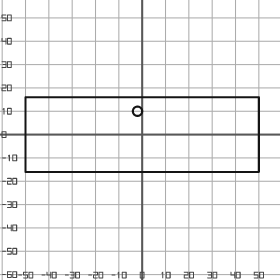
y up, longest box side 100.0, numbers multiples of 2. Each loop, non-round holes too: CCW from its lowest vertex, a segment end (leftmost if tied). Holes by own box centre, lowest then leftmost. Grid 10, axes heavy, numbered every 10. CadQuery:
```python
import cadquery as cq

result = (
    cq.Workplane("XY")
    .moveTo(-50.0, -16.0)
    .lineTo(50.0, -16.0)
    .lineTo(50.0, 16.0)
    .lineTo(-50.0, 16.0)
    .close()
    .moveTo(-2.0, 10.0)
    .circle(2.0)
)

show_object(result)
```